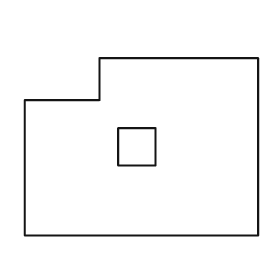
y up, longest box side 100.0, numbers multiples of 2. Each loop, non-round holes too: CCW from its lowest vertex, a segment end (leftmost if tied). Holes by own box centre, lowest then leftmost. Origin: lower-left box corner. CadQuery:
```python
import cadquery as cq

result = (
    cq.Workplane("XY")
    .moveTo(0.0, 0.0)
    .lineTo(100.0, 0.0)
    .lineTo(100.0, 76.0)
    .lineTo(32.0, 76.0)
    .lineTo(32.0, 58.0)
    .lineTo(0.0, 58.0)
    .close()
    .moveTo(40.0, 30.0)
    .lineTo(56.0, 30.0)
    .lineTo(56.0, 46.0)
    .lineTo(40.0, 46.0)
    .close()
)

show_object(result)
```